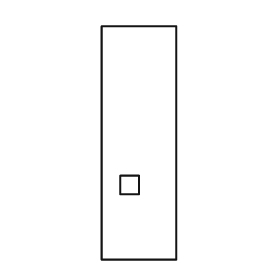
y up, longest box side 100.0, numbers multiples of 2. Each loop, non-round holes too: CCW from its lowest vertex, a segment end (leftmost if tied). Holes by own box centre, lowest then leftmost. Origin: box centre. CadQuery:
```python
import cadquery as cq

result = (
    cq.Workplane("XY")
    .moveTo(-16.0, -50.0)
    .lineTo(16.0, -50.0)
    .lineTo(16.0, 50.0)
    .lineTo(-16.0, 50.0)
    .close()
    .moveTo(-8.0, -22.0)
    .lineTo(0.0, -22.0)
    .lineTo(0.0, -14.0)
    .lineTo(-8.0, -14.0)
    .close()
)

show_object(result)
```